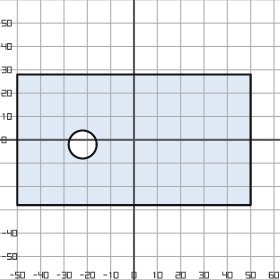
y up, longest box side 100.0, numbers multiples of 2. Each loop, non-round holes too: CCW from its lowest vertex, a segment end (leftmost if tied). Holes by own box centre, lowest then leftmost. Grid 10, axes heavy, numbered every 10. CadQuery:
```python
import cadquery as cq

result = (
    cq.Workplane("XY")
    .moveTo(-50.0, -28.0)
    .lineTo(50.0, -28.0)
    .lineTo(50.0, 28.0)
    .lineTo(-50.0, 28.0)
    .close()
    .moveTo(-22.0, -2.0)
    .circle(6.0)
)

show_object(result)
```